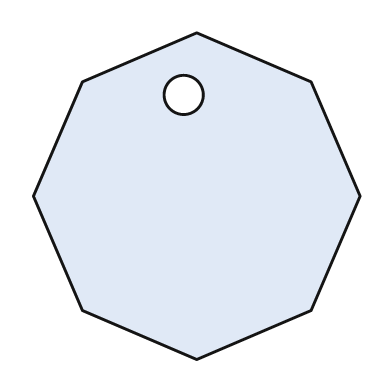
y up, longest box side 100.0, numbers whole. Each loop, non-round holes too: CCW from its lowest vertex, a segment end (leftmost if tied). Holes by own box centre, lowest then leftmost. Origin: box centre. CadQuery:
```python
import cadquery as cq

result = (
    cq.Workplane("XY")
    .moveTo(0.0, -50.0)
    .lineTo(35.0, -35.0)
    .lineTo(50.0, 0.0)
    .lineTo(35.0, 35.0)
    .lineTo(0.0, 50.0)
    .lineTo(-35.0, 35.0)
    .lineTo(-50.0, 0.0)
    .lineTo(-35.0, -35.0)
    .close()
    .moveTo(-4.0, 31.0)
    .circle(6.0)
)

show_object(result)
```